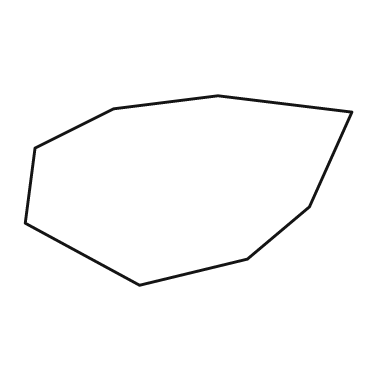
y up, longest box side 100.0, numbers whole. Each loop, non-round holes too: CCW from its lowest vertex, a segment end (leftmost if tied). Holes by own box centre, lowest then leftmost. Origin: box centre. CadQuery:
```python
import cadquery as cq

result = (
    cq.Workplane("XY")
    .moveTo(-15.0, -29.0)
    .lineTo(18.0, -21.0)
    .lineTo(37.0, -5.0)
    .lineTo(50.0, 24.0)
    .lineTo(9.0, 29.0)
    .lineTo(-23.0, 25.0)
    .lineTo(-47.0, 13.0)
    .lineTo(-50.0, -10.0)
    .close()
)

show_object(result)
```